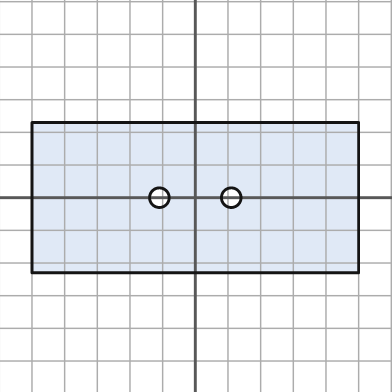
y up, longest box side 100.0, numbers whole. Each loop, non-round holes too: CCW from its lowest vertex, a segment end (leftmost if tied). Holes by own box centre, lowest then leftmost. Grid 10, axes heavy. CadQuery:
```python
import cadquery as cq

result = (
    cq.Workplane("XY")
    .moveTo(-50.0, -23.0)
    .lineTo(50.0, -23.0)
    .lineTo(50.0, 23.0)
    .lineTo(-50.0, 23.0)
    .close()
    .moveTo(-11.0, 0.0)
    .circle(3.0)
    .moveTo(11.0, 0.0)
    .circle(3.0)
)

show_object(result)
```